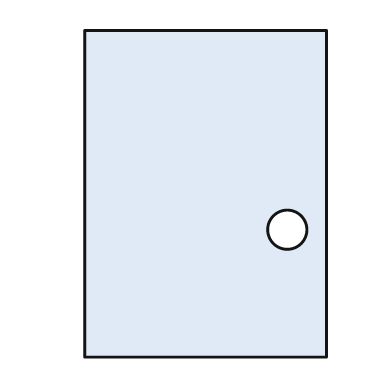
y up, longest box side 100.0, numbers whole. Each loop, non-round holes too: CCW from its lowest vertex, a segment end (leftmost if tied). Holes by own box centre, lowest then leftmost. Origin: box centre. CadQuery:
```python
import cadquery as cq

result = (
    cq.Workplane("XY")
    .moveTo(-37.0, -50.0)
    .lineTo(37.0, -50.0)
    .lineTo(37.0, 50.0)
    .lineTo(-37.0, 50.0)
    .close()
    .moveTo(25.0, -11.0)
    .circle(6.0)
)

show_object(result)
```